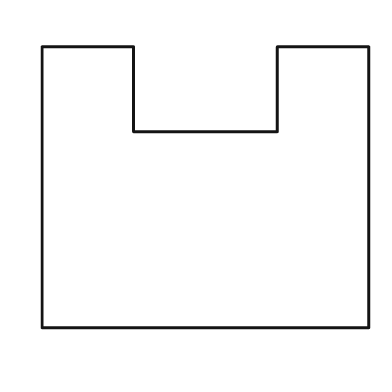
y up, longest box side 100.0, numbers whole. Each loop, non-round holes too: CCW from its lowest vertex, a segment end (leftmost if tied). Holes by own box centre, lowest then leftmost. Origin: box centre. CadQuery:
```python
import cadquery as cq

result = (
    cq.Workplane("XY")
    .moveTo(-50.0, -43.0)
    .lineTo(50.0, -43.0)
    .lineTo(50.0, 43.0)
    .lineTo(22.0, 43.0)
    .lineTo(22.0, 17.0)
    .lineTo(-22.0, 17.0)
    .lineTo(-22.0, 43.0)
    .lineTo(-50.0, 43.0)
    .close()
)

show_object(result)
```